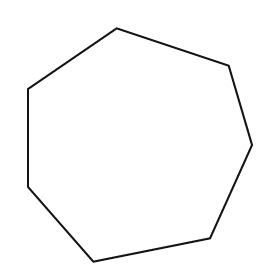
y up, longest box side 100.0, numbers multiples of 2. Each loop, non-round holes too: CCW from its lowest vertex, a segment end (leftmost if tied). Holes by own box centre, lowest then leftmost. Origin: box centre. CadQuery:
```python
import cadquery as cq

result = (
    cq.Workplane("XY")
    .moveTo(-20.0, -50.0)
    .lineTo(30.0, -40.0)
    .lineTo(48.0, 0.0)
    .lineTo(38.0, 34.0)
    .lineTo(-10.0, 50.0)
    .lineTo(-48.0, 24.0)
    .lineTo(-48.0, -18.0)
    .close()
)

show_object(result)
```